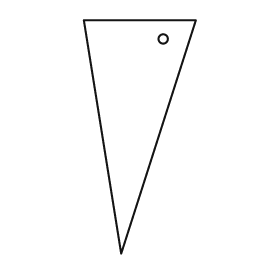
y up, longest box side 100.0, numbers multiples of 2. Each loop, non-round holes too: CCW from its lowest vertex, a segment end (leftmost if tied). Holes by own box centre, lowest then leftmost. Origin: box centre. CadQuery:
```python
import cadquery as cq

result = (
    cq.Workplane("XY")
    .moveTo(-8.0, -50.0)
    .lineTo(24.0, 50.0)
    .lineTo(-24.0, 50.0)
    .close()
    .moveTo(10.0, 42.0)
    .circle(2.0)
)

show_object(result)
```